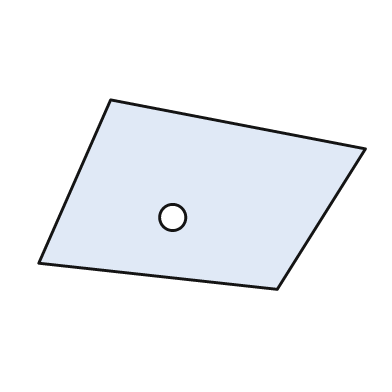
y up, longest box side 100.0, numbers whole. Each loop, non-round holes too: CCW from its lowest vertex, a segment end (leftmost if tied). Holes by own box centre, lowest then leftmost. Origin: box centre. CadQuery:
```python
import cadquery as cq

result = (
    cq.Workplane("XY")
    .moveTo(23.0, -29.0)
    .lineTo(50.0, 14.0)
    .lineTo(-28.0, 29.0)
    .lineTo(-50.0, -21.0)
    .close()
    .moveTo(-9.0, -7.0)
    .circle(4.0)
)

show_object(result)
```